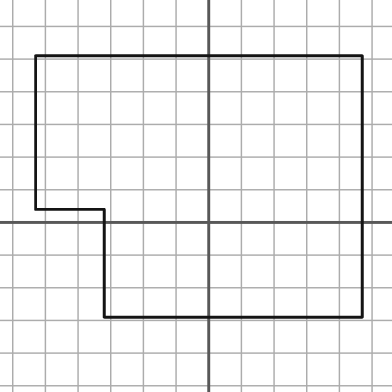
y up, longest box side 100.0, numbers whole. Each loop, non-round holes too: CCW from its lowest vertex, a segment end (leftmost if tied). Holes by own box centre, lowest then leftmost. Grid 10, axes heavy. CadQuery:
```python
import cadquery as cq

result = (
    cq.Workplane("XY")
    .moveTo(-32.0, -29.0)
    .lineTo(47.0, -29.0)
    .lineTo(47.0, 51.0)
    .lineTo(-53.0, 51.0)
    .lineTo(-53.0, 4.0)
    .lineTo(-32.0, 4.0)
    .close()
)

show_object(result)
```